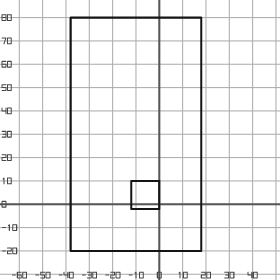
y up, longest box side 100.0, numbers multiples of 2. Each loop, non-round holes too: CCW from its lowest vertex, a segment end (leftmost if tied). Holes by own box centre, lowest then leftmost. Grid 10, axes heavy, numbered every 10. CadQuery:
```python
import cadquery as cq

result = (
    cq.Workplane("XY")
    .moveTo(-38.0, -20.0)
    .lineTo(18.0, -20.0)
    .lineTo(18.0, 80.0)
    .lineTo(-38.0, 80.0)
    .close()
    .moveTo(-12.0, -2.0)
    .lineTo(0.0, -2.0)
    .lineTo(0.0, 10.0)
    .lineTo(-12.0, 10.0)
    .close()
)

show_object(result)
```